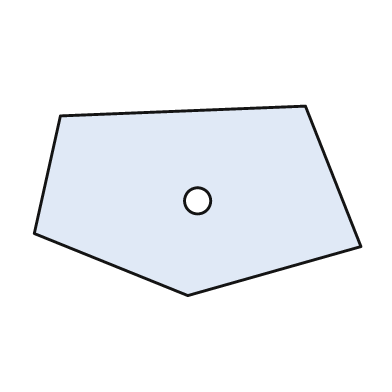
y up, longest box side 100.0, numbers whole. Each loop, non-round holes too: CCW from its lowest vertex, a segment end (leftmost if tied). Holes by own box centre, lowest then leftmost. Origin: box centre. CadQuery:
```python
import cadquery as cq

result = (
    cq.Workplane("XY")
    .moveTo(-3.0, -29.0)
    .lineTo(50.0, -14.0)
    .lineTo(33.0, 29.0)
    .lineTo(-42.0, 26.0)
    .lineTo(-50.0, -10.0)
    .close()
    .moveTo(0.0, 0.0)
    .circle(4.0)
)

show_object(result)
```